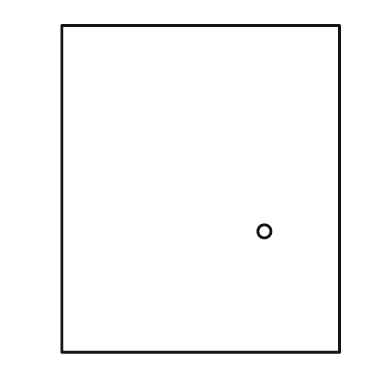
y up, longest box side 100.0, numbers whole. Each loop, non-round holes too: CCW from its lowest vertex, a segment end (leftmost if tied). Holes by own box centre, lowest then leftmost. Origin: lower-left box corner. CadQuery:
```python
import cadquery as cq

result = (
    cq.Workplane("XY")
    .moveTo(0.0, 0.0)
    .lineTo(85.0, 0.0)
    .lineTo(85.0, 100.0)
    .lineTo(0.0, 100.0)
    .close()
    .moveTo(62.0, 37.0)
    .circle(2.0)
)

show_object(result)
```